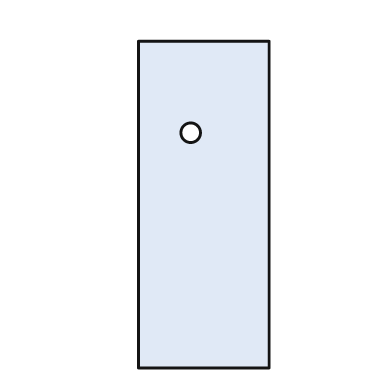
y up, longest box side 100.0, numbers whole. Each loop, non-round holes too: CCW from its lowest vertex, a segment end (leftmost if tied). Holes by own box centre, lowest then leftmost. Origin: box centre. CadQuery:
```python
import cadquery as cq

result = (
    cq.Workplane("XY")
    .moveTo(-20.0, -50.0)
    .lineTo(20.0, -50.0)
    .lineTo(20.0, 50.0)
    .lineTo(-20.0, 50.0)
    .close()
    .moveTo(-4.0, 22.0)
    .circle(3.0)
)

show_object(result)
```